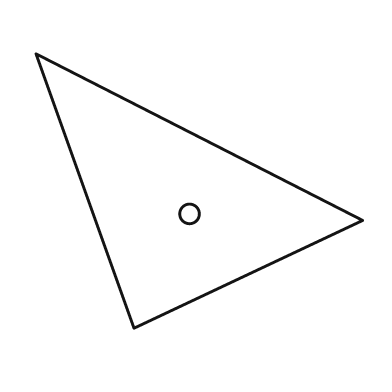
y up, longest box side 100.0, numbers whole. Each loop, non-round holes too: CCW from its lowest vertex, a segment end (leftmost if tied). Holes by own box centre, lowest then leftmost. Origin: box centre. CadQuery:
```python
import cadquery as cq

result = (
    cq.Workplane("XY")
    .moveTo(-20.0, -42.0)
    .lineTo(50.0, -9.0)
    .lineTo(-50.0, 42.0)
    .close()
    .moveTo(-3.0, -7.0)
    .circle(3.0)
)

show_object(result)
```